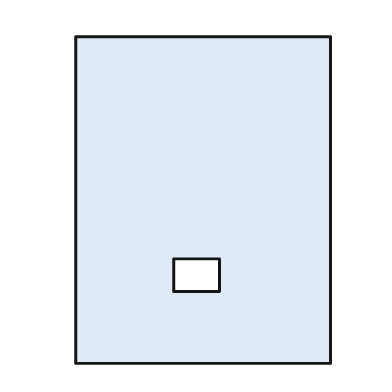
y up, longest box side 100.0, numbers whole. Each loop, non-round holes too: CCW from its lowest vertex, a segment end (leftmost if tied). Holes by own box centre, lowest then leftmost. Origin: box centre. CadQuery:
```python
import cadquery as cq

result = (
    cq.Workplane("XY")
    .moveTo(-39.0, -50.0)
    .lineTo(39.0, -50.0)
    .lineTo(39.0, 50.0)
    .lineTo(-39.0, 50.0)
    .close()
    .moveTo(-9.0, -28.0)
    .lineTo(5.0, -28.0)
    .lineTo(5.0, -18.0)
    .lineTo(-9.0, -18.0)
    .close()
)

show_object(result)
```